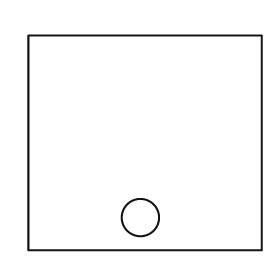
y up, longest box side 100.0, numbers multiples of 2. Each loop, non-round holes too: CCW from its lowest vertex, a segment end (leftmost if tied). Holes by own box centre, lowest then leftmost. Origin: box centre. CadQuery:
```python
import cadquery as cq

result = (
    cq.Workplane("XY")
    .moveTo(-50.0, -46.0)
    .lineTo(50.0, -46.0)
    .lineTo(50.0, 46.0)
    .lineTo(-50.0, 46.0)
    .close()
    .moveTo(-2.0, -32.0)
    .circle(8.0)
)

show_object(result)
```